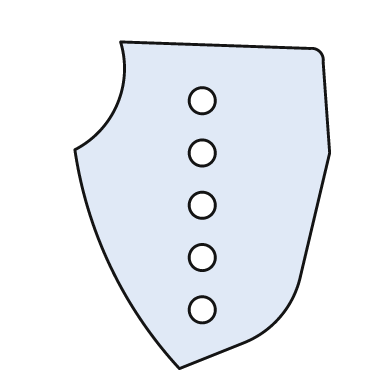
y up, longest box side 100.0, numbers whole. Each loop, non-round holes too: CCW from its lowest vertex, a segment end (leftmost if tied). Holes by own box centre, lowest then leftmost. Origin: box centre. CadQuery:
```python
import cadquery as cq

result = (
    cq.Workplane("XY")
    .moveTo(-7.0, -50.0)
    .lineTo(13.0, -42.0)
    .threePointArc((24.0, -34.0), (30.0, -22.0))
    .lineTo(39.0, 16.0)
    .lineTo(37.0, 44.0)
    .threePointArc((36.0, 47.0), (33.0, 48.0))
    .lineTo(-25.0, 50.0)
    .threePointArc((-26.0, 31.0), (-39.0, 17.0))
    .threePointArc((-28.0, -19.0), (-7.0, -50.0))
    .close()
    .moveTo(0.0, -32.0)
    .circle(4.0)
    .moveTo(0.0, -16.0)
    .circle(4.0)
    .moveTo(0.0, 0.0)
    .circle(4.0)
    .moveTo(0.0, 16.0)
    .circle(4.0)
    .moveTo(0.0, 32.0)
    .circle(4.0)
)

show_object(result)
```